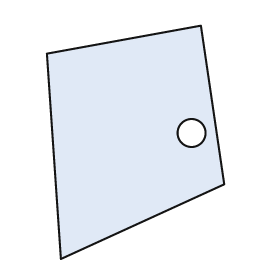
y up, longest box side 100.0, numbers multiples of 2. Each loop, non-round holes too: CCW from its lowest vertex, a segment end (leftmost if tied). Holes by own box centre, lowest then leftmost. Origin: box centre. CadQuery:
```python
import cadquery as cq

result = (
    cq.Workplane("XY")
    .moveTo(-32.0, -50.0)
    .lineTo(38.0, -18.0)
    .lineTo(28.0, 50.0)
    .lineTo(-38.0, 38.0)
    .close()
    .moveTo(24.0, 4.0)
    .circle(6.0)
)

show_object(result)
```